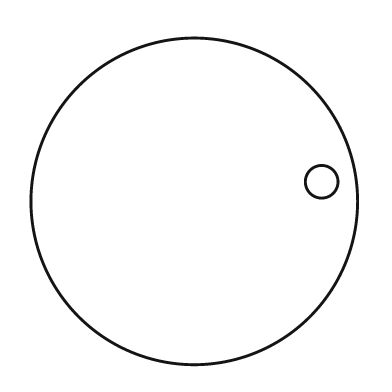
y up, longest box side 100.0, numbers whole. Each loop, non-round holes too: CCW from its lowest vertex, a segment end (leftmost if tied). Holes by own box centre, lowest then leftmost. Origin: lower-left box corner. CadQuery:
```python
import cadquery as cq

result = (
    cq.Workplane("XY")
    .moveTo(50.0, 50.0)
    .circle(50.0)
    .moveTo(89.0, 56.0)
    .circle(5.0)
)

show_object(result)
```